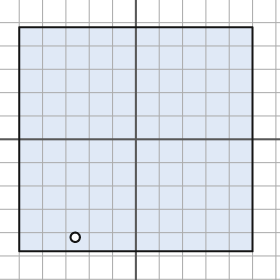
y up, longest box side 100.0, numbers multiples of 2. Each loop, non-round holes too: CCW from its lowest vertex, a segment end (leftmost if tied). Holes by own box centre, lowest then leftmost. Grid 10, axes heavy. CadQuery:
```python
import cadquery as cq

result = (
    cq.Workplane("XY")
    .moveTo(-50.0, -48.0)
    .lineTo(50.0, -48.0)
    .lineTo(50.0, 48.0)
    .lineTo(-50.0, 48.0)
    .close()
    .moveTo(-26.0, -42.0)
    .circle(2.0)
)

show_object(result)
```